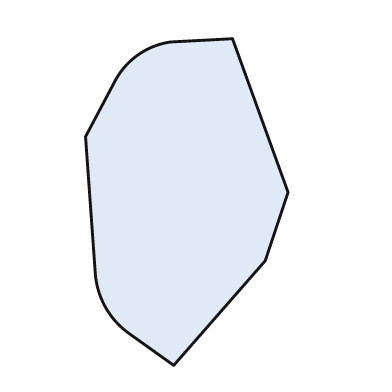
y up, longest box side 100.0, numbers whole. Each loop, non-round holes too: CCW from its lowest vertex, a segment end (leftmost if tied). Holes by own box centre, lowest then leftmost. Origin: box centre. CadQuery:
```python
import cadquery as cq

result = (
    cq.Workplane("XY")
    .moveTo(-4.0, -50.0)
    .lineTo(24.0, -18.0)
    .lineTo(31.0, 3.0)
    .lineTo(14.0, 50.0)
    .lineTo(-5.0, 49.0)
    .threePointArc((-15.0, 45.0), (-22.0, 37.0))
    .lineTo(-31.0, 20.0)
    .lineTo(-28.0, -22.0)
    .threePointArc((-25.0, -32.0), (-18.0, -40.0))
    .close()
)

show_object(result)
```